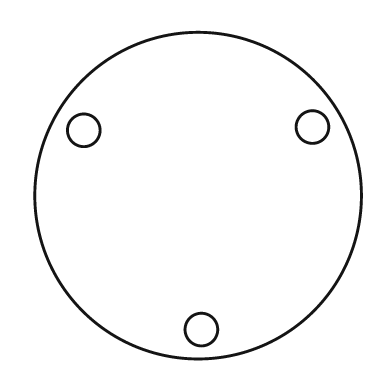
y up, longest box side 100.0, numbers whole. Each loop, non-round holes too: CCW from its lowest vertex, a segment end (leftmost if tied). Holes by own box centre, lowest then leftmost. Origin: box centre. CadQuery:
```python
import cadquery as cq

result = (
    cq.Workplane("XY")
    .moveTo(0.0, 0.0)
    .circle(50.0)
    .moveTo(1.0, -41.0)
    .circle(5.0)
    .moveTo(-35.0, 20.0)
    .circle(5.0)
    .moveTo(35.0, 21.0)
    .circle(5.0)
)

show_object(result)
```